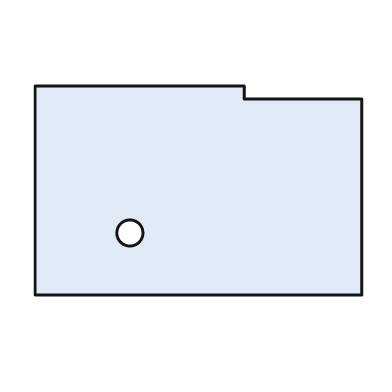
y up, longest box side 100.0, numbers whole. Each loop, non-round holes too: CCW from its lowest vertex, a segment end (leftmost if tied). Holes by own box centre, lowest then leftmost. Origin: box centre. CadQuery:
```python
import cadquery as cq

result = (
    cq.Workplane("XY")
    .moveTo(-50.0, -32.0)
    .lineTo(50.0, -32.0)
    .lineTo(50.0, 28.0)
    .lineTo(14.0, 28.0)
    .lineTo(14.0, 32.0)
    .lineTo(-50.0, 32.0)
    .close()
    .moveTo(-21.0, -13.0)
    .circle(4.0)
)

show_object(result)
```